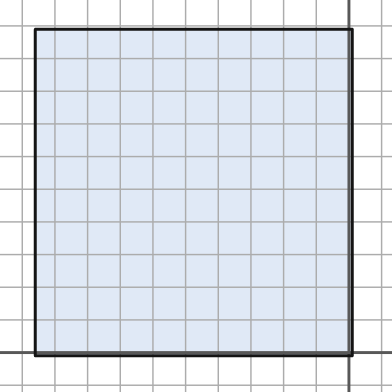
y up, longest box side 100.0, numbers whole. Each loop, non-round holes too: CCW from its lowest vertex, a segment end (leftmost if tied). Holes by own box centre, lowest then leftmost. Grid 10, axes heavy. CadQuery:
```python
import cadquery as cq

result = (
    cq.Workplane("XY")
    .moveTo(-96.0, -1.0)
    .lineTo(1.0, -1.0)
    .lineTo(1.0, 99.0)
    .lineTo(-96.0, 99.0)
    .close()
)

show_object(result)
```